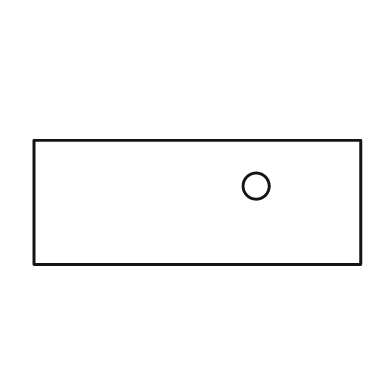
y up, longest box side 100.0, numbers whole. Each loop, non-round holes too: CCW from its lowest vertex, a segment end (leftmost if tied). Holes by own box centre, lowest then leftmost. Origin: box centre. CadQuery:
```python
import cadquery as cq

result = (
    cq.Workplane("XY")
    .moveTo(-50.0, -19.0)
    .lineTo(50.0, -19.0)
    .lineTo(50.0, 19.0)
    .lineTo(-50.0, 19.0)
    .close()
    .moveTo(18.0, 5.0)
    .circle(4.0)
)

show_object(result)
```